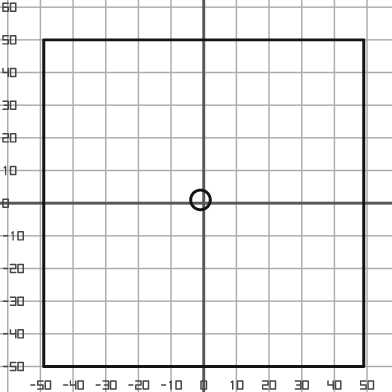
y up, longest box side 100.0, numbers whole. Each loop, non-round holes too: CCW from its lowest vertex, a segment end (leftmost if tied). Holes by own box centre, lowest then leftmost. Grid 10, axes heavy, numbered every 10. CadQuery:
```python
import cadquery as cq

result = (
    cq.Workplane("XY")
    .moveTo(-49.0, -50.0)
    .lineTo(49.0, -50.0)
    .lineTo(49.0, 50.0)
    .lineTo(-49.0, 50.0)
    .close()
    .moveTo(-1.0, 1.0)
    .circle(3.0)
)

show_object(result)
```